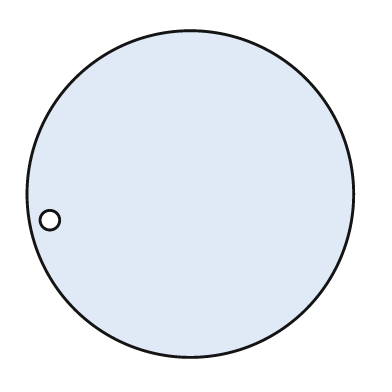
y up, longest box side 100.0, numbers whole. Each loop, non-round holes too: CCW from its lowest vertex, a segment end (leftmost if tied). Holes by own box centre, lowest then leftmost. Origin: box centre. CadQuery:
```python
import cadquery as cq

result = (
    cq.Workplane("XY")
    .moveTo(0.0, 0.0)
    .circle(50.0)
    .moveTo(-43.0, -8.0)
    .circle(3.0)
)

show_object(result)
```